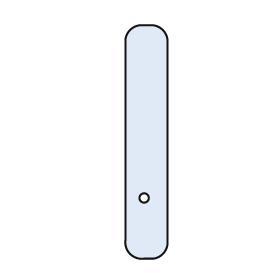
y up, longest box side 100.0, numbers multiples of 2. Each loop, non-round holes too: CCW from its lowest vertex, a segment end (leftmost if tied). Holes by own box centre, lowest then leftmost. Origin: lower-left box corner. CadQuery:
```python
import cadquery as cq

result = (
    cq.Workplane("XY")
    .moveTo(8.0, 0.0)
    .lineTo(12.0, 0.0)
    .threePointArc((16.0, 2.0), (18.0, 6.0))
    .lineTo(18.0, 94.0)
    .threePointArc((16.0, 98.0), (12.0, 100.0))
    .lineTo(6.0, 100.0)
    .threePointArc((2.0, 98.0), (0.0, 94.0))
    .lineTo(0.0, 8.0)
    .threePointArc((2.0, 2.0), (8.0, 0.0))
    .close()
    .moveTo(8.0, 26.0)
    .circle(2.0)
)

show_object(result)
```